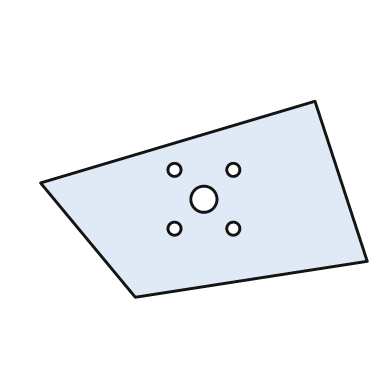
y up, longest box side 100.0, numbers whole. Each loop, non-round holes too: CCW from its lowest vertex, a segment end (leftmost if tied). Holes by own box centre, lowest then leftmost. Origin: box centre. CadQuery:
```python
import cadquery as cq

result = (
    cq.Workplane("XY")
    .moveTo(-21.0, -30.0)
    .lineTo(50.0, -19.0)
    .lineTo(34.0, 30.0)
    .lineTo(-50.0, 5.0)
    .close()
    .moveTo(-9.0, -9.0)
    .circle(2.0)
    .moveTo(9.0, -9.0)
    .circle(2.0)
    .moveTo(0.0, 0.0)
    .circle(4.0)
    .moveTo(-9.0, 9.0)
    .circle(2.0)
    .moveTo(9.0, 9.0)
    .circle(2.0)
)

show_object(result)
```